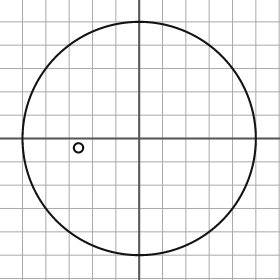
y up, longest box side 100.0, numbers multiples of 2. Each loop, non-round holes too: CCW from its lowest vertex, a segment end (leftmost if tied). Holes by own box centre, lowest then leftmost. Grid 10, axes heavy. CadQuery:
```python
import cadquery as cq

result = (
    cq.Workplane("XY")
    .moveTo(0.0, 0.0)
    .circle(50.0)
    .moveTo(-26.0, -4.0)
    .circle(2.0)
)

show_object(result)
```